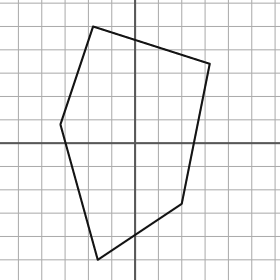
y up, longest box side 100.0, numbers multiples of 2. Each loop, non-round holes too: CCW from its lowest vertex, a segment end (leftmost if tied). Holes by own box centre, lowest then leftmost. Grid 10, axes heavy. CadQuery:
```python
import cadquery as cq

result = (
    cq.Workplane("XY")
    .moveTo(-16.0, -50.0)
    .lineTo(20.0, -26.0)
    .lineTo(32.0, 34.0)
    .lineTo(-18.0, 50.0)
    .lineTo(-32.0, 8.0)
    .close()
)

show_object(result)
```